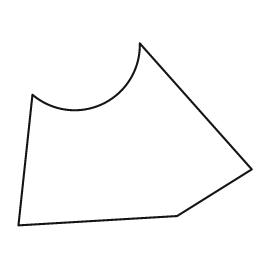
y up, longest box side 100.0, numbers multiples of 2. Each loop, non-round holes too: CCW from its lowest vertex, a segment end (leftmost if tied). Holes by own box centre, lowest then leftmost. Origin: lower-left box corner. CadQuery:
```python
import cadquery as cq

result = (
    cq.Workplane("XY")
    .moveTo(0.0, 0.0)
    .lineTo(68.0, 4.0)
    .lineTo(100.0, 24.0)
    .lineTo(52.0, 78.0)
    .threePointArc((36.0, 52.0), (6.0, 56.0))
    .close()
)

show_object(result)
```